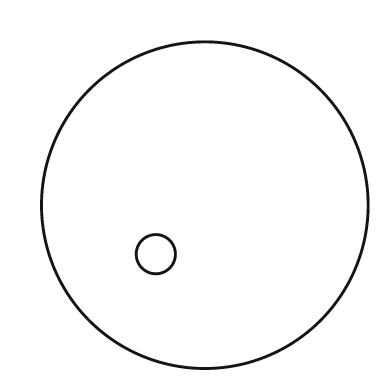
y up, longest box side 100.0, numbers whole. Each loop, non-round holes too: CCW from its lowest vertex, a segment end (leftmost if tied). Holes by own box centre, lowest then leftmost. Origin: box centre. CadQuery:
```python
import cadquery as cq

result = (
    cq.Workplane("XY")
    .moveTo(0.0, 0.0)
    .circle(50.0)
    .moveTo(-15.0, -15.0)
    .circle(6.0)
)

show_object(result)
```